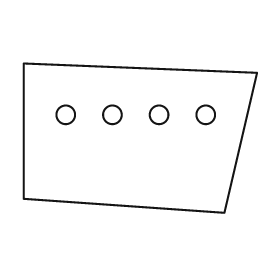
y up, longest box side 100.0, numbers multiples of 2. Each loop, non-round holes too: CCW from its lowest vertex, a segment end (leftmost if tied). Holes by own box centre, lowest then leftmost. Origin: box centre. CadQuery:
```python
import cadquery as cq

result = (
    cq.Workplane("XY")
    .moveTo(36.0, -32.0)
    .lineTo(50.0, 28.0)
    .lineTo(-50.0, 32.0)
    .lineTo(-50.0, -26.0)
    .close()
    .moveTo(-32.0, 10.0)
    .circle(4.0)
    .moveTo(-12.0, 10.0)
    .circle(4.0)
    .moveTo(8.0, 10.0)
    .circle(4.0)
    .moveTo(28.0, 10.0)
    .circle(4.0)
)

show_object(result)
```